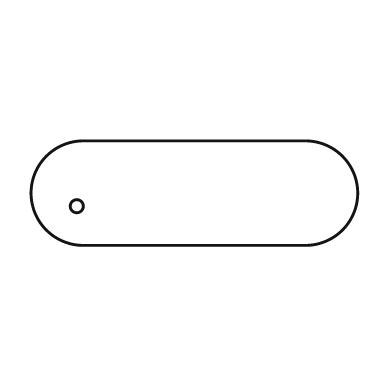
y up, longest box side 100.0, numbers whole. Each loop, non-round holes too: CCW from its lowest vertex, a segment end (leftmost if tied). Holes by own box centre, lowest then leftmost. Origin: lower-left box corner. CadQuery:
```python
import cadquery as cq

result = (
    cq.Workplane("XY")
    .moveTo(16.0, 0.0)
    .lineTo(84.0, 0.0)
    .threePointArc((100.0, 16.0), (84.0, 32.0))
    .lineTo(16.0, 32.0)
    .threePointArc((0.0, 16.0), (16.0, 0.0))
    .close()
    .moveTo(14.0, 12.0)
    .circle(2.0)
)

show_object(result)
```